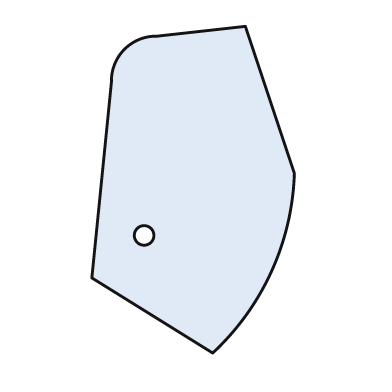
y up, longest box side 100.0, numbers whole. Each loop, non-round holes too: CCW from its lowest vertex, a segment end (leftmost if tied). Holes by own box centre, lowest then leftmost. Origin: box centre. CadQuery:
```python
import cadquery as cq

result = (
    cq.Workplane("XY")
    .moveTo(6.0, -50.0)
    .threePointArc((24.0, -25.0), (31.0, 5.0))
    .lineTo(16.0, 50.0)
    .lineTo(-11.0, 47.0)
    .threePointArc((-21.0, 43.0), (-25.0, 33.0))
    .lineTo(-31.0, -27.0)
    .close()
    .moveTo(-15.0, -14.0)
    .circle(3.0)
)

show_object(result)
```